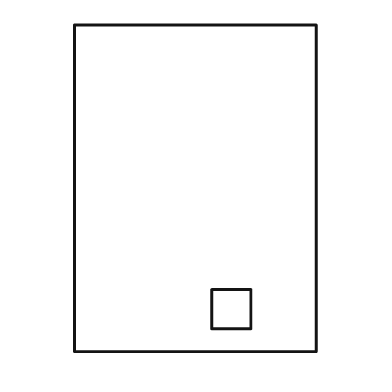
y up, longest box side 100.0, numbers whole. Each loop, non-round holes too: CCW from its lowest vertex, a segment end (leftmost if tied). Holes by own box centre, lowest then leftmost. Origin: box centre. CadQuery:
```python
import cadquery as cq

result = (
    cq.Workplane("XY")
    .moveTo(-37.0, -50.0)
    .lineTo(37.0, -50.0)
    .lineTo(37.0, 50.0)
    .lineTo(-37.0, 50.0)
    .close()
    .moveTo(5.0, -43.0)
    .lineTo(17.0, -43.0)
    .lineTo(17.0, -31.0)
    .lineTo(5.0, -31.0)
    .close()
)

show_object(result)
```